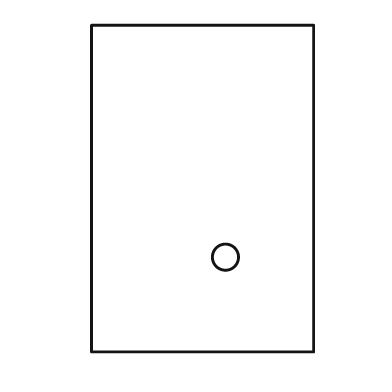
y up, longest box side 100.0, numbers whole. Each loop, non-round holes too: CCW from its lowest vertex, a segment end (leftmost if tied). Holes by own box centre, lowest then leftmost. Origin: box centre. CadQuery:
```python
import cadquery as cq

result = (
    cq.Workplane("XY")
    .moveTo(-34.0, -50.0)
    .lineTo(34.0, -50.0)
    .lineTo(34.0, 50.0)
    .lineTo(-34.0, 50.0)
    .close()
    .moveTo(7.0, -21.0)
    .circle(4.0)
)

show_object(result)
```